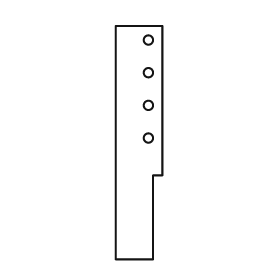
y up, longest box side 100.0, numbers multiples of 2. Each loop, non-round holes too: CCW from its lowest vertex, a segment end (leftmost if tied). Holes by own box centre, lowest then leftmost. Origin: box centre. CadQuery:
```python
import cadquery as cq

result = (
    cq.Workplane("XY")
    .moveTo(-10.0, -50.0)
    .lineTo(6.0, -50.0)
    .lineTo(6.0, -14.0)
    .lineTo(10.0, -14.0)
    .lineTo(10.0, 50.0)
    .lineTo(-10.0, 50.0)
    .close()
    .moveTo(4.0, 2.0)
    .circle(2.0)
    .moveTo(4.0, 16.0)
    .circle(2.0)
    .moveTo(4.0, 30.0)
    .circle(2.0)
    .moveTo(4.0, 44.0)
    .circle(2.0)
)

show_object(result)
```